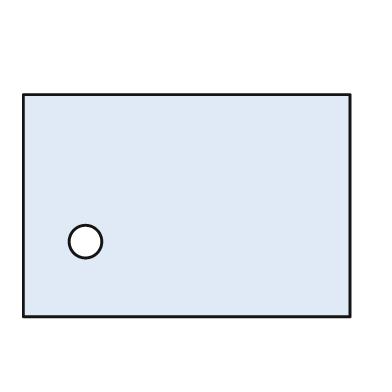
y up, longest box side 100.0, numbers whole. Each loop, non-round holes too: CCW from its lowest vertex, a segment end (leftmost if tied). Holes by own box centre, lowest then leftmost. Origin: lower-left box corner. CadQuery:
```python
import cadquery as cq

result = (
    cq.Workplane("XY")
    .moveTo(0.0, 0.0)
    .lineTo(100.0, 0.0)
    .lineTo(100.0, 68.0)
    .lineTo(0.0, 68.0)
    .close()
    .moveTo(19.0, 23.0)
    .circle(5.0)
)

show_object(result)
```